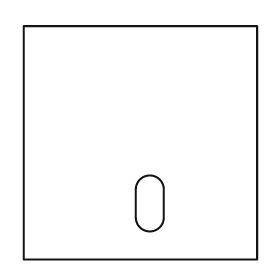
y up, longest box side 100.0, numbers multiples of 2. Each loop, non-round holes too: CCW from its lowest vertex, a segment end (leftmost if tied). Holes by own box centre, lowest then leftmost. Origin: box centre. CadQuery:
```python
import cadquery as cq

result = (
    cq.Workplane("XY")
    .moveTo(-50.0, -50.0)
    .lineTo(50.0, -50.0)
    .lineTo(50.0, 50.0)
    .lineTo(-50.0, 50.0)
    .close()
    .moveTo(-2.0, -32.0)
    .threePointArc((4.0, -38.0), (10.0, -32.0))
    .lineTo(10.0, -20.0)
    .threePointArc((4.0, -14.0), (-2.0, -20.0))
    .close()
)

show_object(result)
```